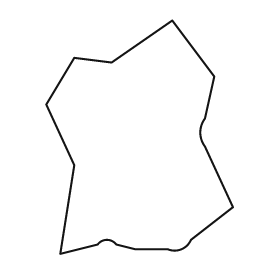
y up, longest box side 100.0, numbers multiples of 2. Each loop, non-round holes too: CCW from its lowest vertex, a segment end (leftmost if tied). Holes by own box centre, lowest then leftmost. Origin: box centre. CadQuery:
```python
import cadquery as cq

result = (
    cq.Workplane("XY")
    .moveTo(-34.0, -50.0)
    .lineTo(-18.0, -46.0)
    .threePointArc((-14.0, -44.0), (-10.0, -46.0))
    .lineTo(-2.0, -48.0)
    .lineTo(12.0, -48.0)
    .threePointArc((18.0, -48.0), (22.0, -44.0))
    .lineTo(40.0, -30.0)
    .lineTo(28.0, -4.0)
    .threePointArc((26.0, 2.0), (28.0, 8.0))
    .lineTo(32.0, 26.0)
    .lineTo(14.0, 50.0)
    .lineTo(-12.0, 32.0)
    .lineTo(-28.0, 34.0)
    .lineTo(-40.0, 14.0)
    .lineTo(-28.0, -12.0)
    .close()
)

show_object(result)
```